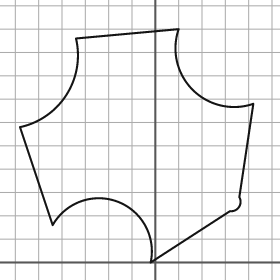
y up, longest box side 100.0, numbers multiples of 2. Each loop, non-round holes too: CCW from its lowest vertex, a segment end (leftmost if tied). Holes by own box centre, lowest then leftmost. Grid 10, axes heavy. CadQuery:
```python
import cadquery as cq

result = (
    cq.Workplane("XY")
    .moveTo(-2.0, 0.0)
    .lineTo(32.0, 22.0)
    .threePointArc((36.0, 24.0), (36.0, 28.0))
    .lineTo(42.0, 68.0)
    .threePointArc((16.0, 74.0), (10.0, 100.0))
    .lineTo(-34.0, 96.0)
    .threePointArc((-38.0, 72.0), (-58.0, 58.0))
    .lineTo(-44.0, 16.0)
    .threePointArc((-16.0, 26.0), (-2.0, 0.0))
    .close()
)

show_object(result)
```